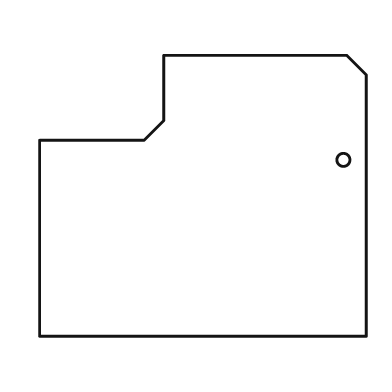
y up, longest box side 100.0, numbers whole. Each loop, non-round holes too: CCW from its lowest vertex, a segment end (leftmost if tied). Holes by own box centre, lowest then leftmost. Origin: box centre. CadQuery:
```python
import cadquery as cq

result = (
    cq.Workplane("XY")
    .moveTo(-50.0, -43.0)
    .lineTo(50.0, -43.0)
    .lineTo(50.0, 37.0)
    .lineTo(44.0, 43.0)
    .lineTo(-12.0, 43.0)
    .lineTo(-12.0, 23.0)
    .lineTo(-18.0, 17.0)
    .lineTo(-50.0, 17.0)
    .close()
    .moveTo(43.0, 11.0)
    .circle(2.0)
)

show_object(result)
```